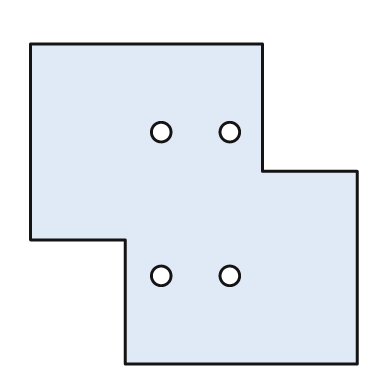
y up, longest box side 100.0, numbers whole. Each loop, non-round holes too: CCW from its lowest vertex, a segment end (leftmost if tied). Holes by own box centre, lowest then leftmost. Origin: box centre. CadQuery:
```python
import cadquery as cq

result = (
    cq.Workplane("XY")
    .moveTo(-21.0, -49.0)
    .lineTo(50.0, -49.0)
    .lineTo(50.0, 10.0)
    .lineTo(21.0, 10.0)
    .lineTo(21.0, 49.0)
    .lineTo(-50.0, 49.0)
    .lineTo(-50.0, -11.0)
    .lineTo(-21.0, -11.0)
    .close()
    .moveTo(-10.0, -22.0)
    .circle(3.0)
    .moveTo(11.0, -22.0)
    .circle(3.0)
    .moveTo(-10.0, 22.0)
    .circle(3.0)
    .moveTo(11.0, 22.0)
    .circle(3.0)
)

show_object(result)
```